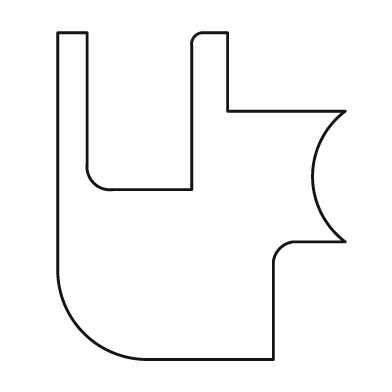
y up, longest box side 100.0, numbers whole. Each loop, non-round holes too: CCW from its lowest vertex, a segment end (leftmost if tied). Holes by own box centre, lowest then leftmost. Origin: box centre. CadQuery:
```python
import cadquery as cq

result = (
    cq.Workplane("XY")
    .moveTo(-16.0, -50.0)
    .lineTo(22.0, -50.0)
    .lineTo(22.0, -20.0)
    .threePointArc((24.0, -16.0), (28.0, -14.0))
    .lineTo(44.0, -14.0)
    .threePointArc((34.0, 6.0), (44.0, 26.0))
    .lineTo(8.0, 26.0)
    .lineTo(8.0, 50.0)
    .lineTo(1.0, 50.0)
    .threePointArc((-2.0, 49.0), (-3.0, 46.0))
    .lineTo(-3.0, 2.0)
    .lineTo(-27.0, 2.0)
    .threePointArc((-33.0, 4.0), (-35.0, 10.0))
    .lineTo(-35.0, 50.0)
    .lineTo(-44.0, 50.0)
    .lineTo(-44.0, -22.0)
    .threePointArc((-36.0, -42.0), (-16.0, -50.0))
    .close()
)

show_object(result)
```